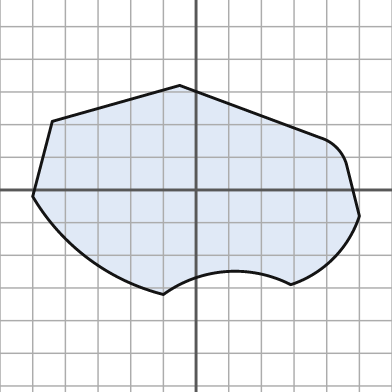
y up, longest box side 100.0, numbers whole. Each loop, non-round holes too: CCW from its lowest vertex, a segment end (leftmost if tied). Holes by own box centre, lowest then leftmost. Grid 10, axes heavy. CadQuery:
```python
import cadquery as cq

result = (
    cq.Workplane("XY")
    .moveTo(-10.0, -32.0)
    .threePointArc((9.0, -25.0), (29.0, -29.0))
    .threePointArc((42.0, -21.0), (50.0, -8.0))
    .lineTo(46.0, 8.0)
    .threePointArc((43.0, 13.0), (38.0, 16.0))
    .lineTo(-5.0, 32.0)
    .lineTo(-44.0, 21.0)
    .lineTo(-50.0, -2.0)
    .threePointArc((-33.0, -21.0), (-10.0, -32.0))
    .close()
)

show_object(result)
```